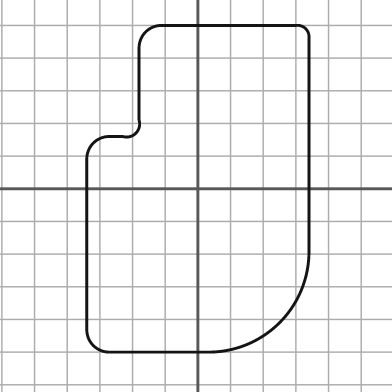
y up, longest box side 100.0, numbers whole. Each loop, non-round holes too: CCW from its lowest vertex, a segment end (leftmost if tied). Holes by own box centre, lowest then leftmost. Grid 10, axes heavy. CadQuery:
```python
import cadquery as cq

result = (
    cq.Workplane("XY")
    .moveTo(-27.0, -50.0)
    .lineTo(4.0, -50.0)
    .threePointArc((25.0, -41.0), (34.0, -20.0))
    .lineTo(34.0, 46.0)
    .threePointArc((33.0, 49.0), (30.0, 50.0))
    .lineTo(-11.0, 50.0)
    .threePointArc((-16.0, 48.0), (-18.0, 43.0))
    .lineTo(-18.0, 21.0)
    .threePointArc((-19.0, 17.0), (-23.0, 16.0))
    .lineTo(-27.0, 16.0)
    .threePointArc((-32.0, 14.0), (-34.0, 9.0))
    .lineTo(-34.0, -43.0)
    .threePointArc((-32.0, -48.0), (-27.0, -50.0))
    .close()
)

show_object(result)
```